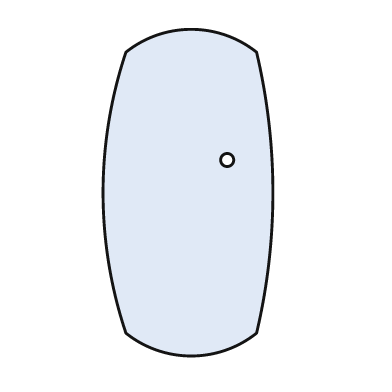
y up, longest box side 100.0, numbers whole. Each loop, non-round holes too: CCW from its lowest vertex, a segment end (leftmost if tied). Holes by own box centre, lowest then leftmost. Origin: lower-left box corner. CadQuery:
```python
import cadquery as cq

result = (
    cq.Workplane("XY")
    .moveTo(7.0, 7.0)
    .threePointArc((27.0, 0.0), (47.0, 7.0))
    .threePointArc((52.0, 50.0), (47.0, 93.0))
    .threePointArc((27.0, 100.0), (7.0, 93.0))
    .threePointArc((0.0, 50.0), (7.0, 7.0))
    .close()
    .moveTo(38.0, 60.0)
    .circle(2.0)
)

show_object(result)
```